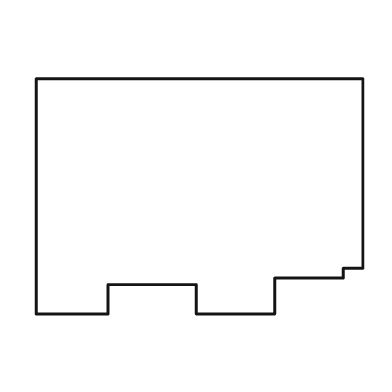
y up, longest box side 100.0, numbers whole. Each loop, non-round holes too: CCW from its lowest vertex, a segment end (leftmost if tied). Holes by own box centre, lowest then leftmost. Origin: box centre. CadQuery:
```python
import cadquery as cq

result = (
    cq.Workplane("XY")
    .moveTo(-50.0, -36.0)
    .lineTo(-28.0, -36.0)
    .lineTo(-28.0, -27.0)
    .lineTo(-1.0, -27.0)
    .lineTo(-1.0, -36.0)
    .lineTo(23.0, -36.0)
    .lineTo(23.0, -25.0)
    .lineTo(44.0, -25.0)
    .lineTo(44.0, -22.0)
    .lineTo(50.0, -22.0)
    .lineTo(50.0, 36.0)
    .lineTo(-50.0, 36.0)
    .close()
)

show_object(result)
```